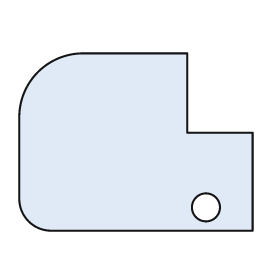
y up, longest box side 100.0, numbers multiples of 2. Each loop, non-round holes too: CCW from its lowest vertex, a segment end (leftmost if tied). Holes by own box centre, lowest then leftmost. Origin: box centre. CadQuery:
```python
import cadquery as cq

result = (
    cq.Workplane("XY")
    .moveTo(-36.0, -38.0)
    .lineTo(50.0, -38.0)
    .lineTo(50.0, 4.0)
    .lineTo(22.0, 4.0)
    .lineTo(22.0, 38.0)
    .lineTo(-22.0, 38.0)
    .threePointArc((-42.0, 30.0), (-50.0, 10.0))
    .lineTo(-50.0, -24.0)
    .threePointArc((-46.0, -34.0), (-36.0, -38.0))
    .close()
    .moveTo(30.0, -28.0)
    .circle(6.0)
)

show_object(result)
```